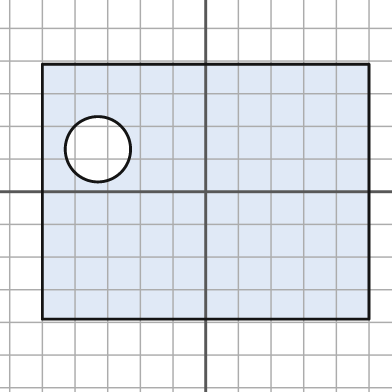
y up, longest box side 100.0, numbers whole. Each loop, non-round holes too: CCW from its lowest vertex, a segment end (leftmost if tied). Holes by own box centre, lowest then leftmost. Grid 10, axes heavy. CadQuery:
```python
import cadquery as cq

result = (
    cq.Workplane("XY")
    .moveTo(-50.0, -39.0)
    .lineTo(50.0, -39.0)
    .lineTo(50.0, 39.0)
    .lineTo(-50.0, 39.0)
    .close()
    .moveTo(-33.0, 13.0)
    .circle(10.0)
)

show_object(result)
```